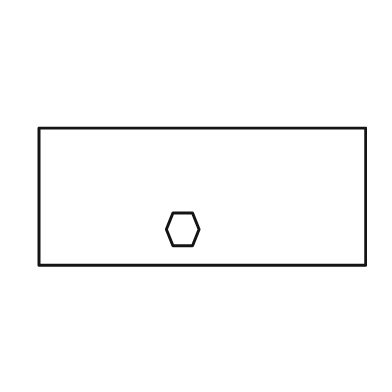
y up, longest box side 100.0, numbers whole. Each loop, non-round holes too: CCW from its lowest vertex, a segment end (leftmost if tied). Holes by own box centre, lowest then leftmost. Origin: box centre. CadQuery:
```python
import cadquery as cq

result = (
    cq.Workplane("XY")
    .moveTo(-50.0, -21.0)
    .lineTo(50.0, -21.0)
    .lineTo(50.0, 21.0)
    .lineTo(-50.0, 21.0)
    .close()
    .moveTo(-9.0, -15.0)
    .lineTo(-3.0, -15.0)
    .lineTo(-1.0, -10.0)
    .lineTo(-3.0, -5.0)
    .lineTo(-9.0, -5.0)
    .lineTo(-11.0, -10.0)
    .close()
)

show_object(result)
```